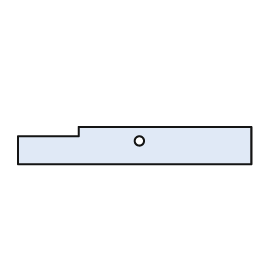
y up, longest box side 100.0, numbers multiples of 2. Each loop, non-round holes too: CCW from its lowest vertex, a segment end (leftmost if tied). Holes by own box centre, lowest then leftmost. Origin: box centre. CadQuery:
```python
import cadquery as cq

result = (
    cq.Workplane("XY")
    .moveTo(-50.0, -8.0)
    .lineTo(50.0, -8.0)
    .lineTo(50.0, 8.0)
    .lineTo(-24.0, 8.0)
    .lineTo(-24.0, 4.0)
    .lineTo(-50.0, 4.0)
    .close()
    .moveTo(2.0, 2.0)
    .circle(2.0)
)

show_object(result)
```